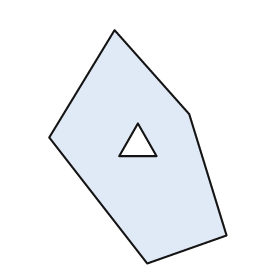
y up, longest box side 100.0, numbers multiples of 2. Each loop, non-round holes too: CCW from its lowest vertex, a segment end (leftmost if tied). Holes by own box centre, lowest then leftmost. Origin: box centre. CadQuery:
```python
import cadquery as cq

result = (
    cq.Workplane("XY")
    .moveTo(4.0, -50.0)
    .lineTo(38.0, -38.0)
    .lineTo(22.0, 14.0)
    .lineTo(-10.0, 50.0)
    .lineTo(-38.0, 4.0)
    .close()
    .moveTo(-8.0, -4.0)
    .lineTo(8.0, -4.0)
    .lineTo(0.0, 10.0)
    .close()
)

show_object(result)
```